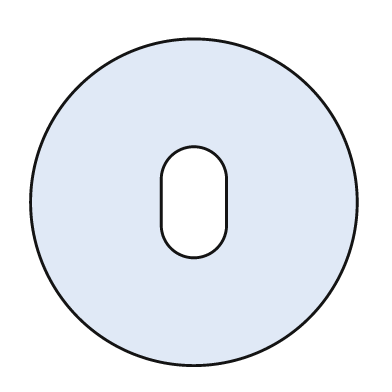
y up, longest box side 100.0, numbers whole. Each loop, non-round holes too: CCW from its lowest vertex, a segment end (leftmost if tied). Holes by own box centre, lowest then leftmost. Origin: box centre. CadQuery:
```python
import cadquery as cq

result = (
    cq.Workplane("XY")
    .moveTo(0.0, 0.0)
    .circle(50.0)
    .moveTo(-10.0, -7.0)
    .threePointArc((0.0, -17.0), (10.0, -7.0))
    .lineTo(10.0, 7.0)
    .threePointArc((0.0, 17.0), (-10.0, 7.0))
    .close()
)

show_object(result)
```